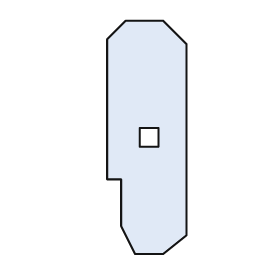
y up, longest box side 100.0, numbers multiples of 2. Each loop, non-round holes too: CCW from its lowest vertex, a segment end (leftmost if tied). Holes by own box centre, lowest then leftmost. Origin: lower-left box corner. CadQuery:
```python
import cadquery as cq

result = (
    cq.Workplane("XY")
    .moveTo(12.0, 0.0)
    .lineTo(24.0, 0.0)
    .lineTo(34.0, 8.0)
    .lineTo(34.0, 90.0)
    .lineTo(24.0, 100.0)
    .lineTo(8.0, 100.0)
    .lineTo(0.0, 92.0)
    .lineTo(0.0, 32.0)
    .lineTo(6.0, 32.0)
    .lineTo(6.0, 12.0)
    .close()
    .moveTo(14.0, 46.0)
    .lineTo(22.0, 46.0)
    .lineTo(22.0, 54.0)
    .lineTo(14.0, 54.0)
    .close()
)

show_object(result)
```